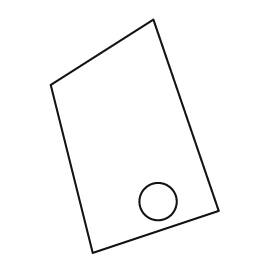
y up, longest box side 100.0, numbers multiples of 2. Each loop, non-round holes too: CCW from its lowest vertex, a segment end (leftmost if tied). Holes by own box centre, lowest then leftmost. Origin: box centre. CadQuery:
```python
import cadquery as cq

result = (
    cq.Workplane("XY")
    .moveTo(-18.0, -50.0)
    .lineTo(36.0, -32.0)
    .lineTo(8.0, 50.0)
    .lineTo(-36.0, 22.0)
    .close()
    .moveTo(10.0, -28.0)
    .circle(8.0)
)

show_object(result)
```